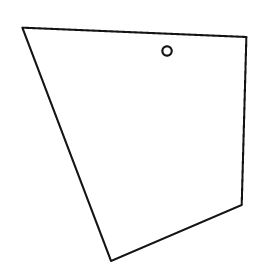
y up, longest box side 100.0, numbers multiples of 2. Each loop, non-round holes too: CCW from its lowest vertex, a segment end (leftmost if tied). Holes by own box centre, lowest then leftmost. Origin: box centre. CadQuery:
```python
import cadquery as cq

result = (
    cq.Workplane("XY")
    .moveTo(-10.0, -50.0)
    .lineTo(46.0, -26.0)
    .lineTo(48.0, 46.0)
    .lineTo(-48.0, 50.0)
    .close()
    .moveTo(14.0, 40.0)
    .circle(2.0)
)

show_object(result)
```